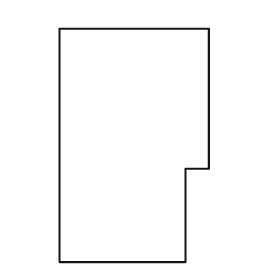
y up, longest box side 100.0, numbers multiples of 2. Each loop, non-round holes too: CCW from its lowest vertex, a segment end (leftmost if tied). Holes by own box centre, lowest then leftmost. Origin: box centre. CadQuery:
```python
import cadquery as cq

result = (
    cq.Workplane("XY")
    .moveTo(-32.0, -50.0)
    .lineTo(22.0, -50.0)
    .lineTo(22.0, -10.0)
    .lineTo(32.0, -10.0)
    .lineTo(32.0, 50.0)
    .lineTo(-32.0, 50.0)
    .close()
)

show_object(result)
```